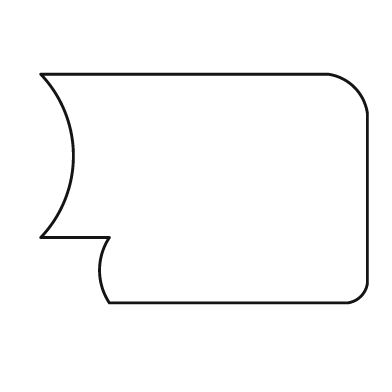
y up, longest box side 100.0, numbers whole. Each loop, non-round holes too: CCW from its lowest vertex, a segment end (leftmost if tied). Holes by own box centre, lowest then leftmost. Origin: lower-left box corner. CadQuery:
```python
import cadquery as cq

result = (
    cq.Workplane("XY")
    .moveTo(21.0, 0.0)
    .lineTo(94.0, 0.0)
    .threePointArc((98.0, 2.0), (100.0, 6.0))
    .lineTo(100.0, 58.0)
    .threePointArc((96.0, 66.0), (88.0, 70.0))
    .lineTo(0.0, 70.0)
    .threePointArc((10.0, 45.0), (0.0, 20.0))
    .lineTo(21.0, 20.0)
    .threePointArc((18.0, 10.0), (21.0, 0.0))
    .close()
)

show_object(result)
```